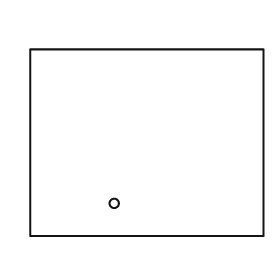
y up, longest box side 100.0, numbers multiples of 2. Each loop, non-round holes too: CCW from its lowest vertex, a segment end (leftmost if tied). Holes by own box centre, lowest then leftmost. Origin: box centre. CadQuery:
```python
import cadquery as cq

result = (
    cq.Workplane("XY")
    .moveTo(-50.0, -40.0)
    .lineTo(50.0, -40.0)
    .lineTo(50.0, 40.0)
    .lineTo(-50.0, 40.0)
    .close()
    .moveTo(-14.0, -26.0)
    .circle(2.0)
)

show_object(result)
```